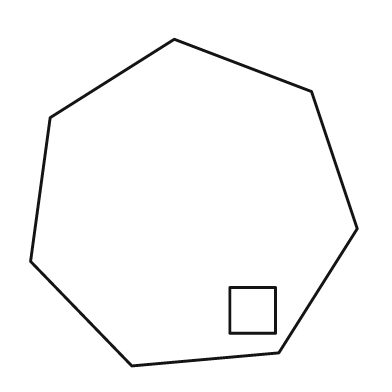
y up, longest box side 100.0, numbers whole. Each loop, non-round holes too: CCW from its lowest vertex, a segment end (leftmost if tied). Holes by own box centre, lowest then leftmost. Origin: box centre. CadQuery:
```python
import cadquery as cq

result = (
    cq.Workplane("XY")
    .moveTo(-19.0, -50.0)
    .lineTo(26.0, -46.0)
    .lineTo(50.0, -8.0)
    .lineTo(36.0, 34.0)
    .lineTo(-6.0, 50.0)
    .lineTo(-44.0, 26.0)
    .lineTo(-50.0, -18.0)
    .close()
    .moveTo(11.0, -40.0)
    .lineTo(25.0, -40.0)
    .lineTo(25.0, -26.0)
    .lineTo(11.0, -26.0)
    .close()
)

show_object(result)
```